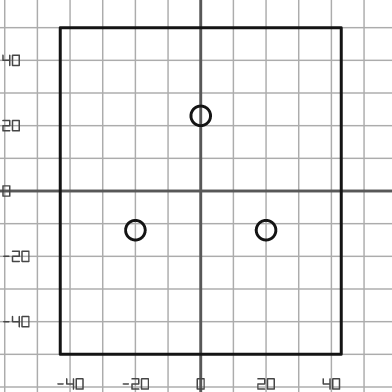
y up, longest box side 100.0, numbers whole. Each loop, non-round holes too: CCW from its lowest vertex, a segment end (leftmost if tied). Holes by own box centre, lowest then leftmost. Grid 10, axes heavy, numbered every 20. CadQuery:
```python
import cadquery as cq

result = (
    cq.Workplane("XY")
    .moveTo(-43.0, -50.0)
    .lineTo(43.0, -50.0)
    .lineTo(43.0, 50.0)
    .lineTo(-43.0, 50.0)
    .close()
    .moveTo(-20.0, -12.0)
    .circle(3.0)
    .moveTo(20.0, -12.0)
    .circle(3.0)
    .moveTo(0.0, 23.0)
    .circle(3.0)
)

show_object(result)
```